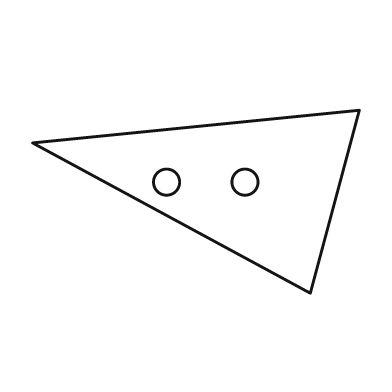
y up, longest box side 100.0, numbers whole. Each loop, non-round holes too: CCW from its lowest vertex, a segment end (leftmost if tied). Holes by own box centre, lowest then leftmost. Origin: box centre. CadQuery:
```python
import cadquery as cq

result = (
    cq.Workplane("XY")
    .moveTo(35.0, -28.0)
    .lineTo(50.0, 28.0)
    .lineTo(-50.0, 18.0)
    .close()
    .moveTo(-9.0, 6.0)
    .circle(4.0)
    .moveTo(15.0, 6.0)
    .circle(4.0)
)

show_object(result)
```